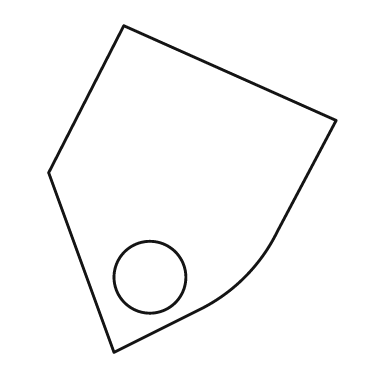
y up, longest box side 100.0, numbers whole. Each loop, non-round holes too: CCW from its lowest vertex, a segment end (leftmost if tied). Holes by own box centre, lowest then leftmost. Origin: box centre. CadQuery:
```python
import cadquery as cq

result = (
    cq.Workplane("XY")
    .moveTo(-24.0, -50.0)
    .lineTo(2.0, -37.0)
    .threePointArc((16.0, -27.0), (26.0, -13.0))
    .lineTo(44.0, 21.0)
    .lineTo(-21.0, 50.0)
    .lineTo(-44.0, 5.0)
    .close()
    .moveTo(-13.0, -27.0)
    .circle(11.0)
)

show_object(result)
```